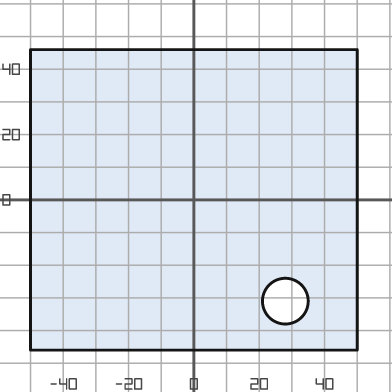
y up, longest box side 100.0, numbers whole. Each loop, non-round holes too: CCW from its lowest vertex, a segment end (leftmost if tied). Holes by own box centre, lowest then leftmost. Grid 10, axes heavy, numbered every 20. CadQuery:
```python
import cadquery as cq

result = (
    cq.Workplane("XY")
    .moveTo(-50.0, -46.0)
    .lineTo(50.0, -46.0)
    .lineTo(50.0, 46.0)
    .lineTo(-50.0, 46.0)
    .close()
    .moveTo(28.0, -31.0)
    .circle(7.0)
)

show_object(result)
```